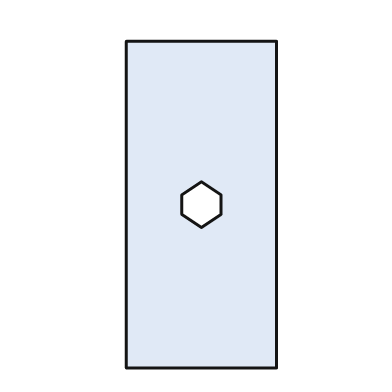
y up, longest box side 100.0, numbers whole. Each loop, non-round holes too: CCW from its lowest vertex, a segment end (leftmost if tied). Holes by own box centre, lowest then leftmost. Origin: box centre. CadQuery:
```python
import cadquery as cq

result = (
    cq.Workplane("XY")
    .moveTo(-23.0, -50.0)
    .lineTo(23.0, -50.0)
    .lineTo(23.0, 50.0)
    .lineTo(-23.0, 50.0)
    .close()
    .moveTo(0.0, -7.0)
    .lineTo(6.0, -3.0)
    .lineTo(6.0, 3.0)
    .lineTo(0.0, 7.0)
    .lineTo(-6.0, 3.0)
    .lineTo(-6.0, -3.0)
    .close()
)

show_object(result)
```